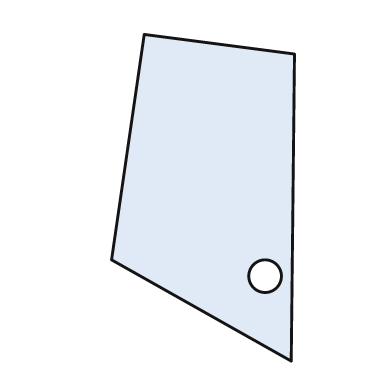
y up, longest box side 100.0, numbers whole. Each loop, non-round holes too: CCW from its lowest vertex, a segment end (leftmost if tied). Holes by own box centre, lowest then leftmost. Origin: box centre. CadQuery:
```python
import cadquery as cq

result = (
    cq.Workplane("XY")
    .moveTo(27.0, -50.0)
    .lineTo(28.0, 44.0)
    .lineTo(-18.0, 50.0)
    .lineTo(-28.0, -19.0)
    .close()
    .moveTo(19.0, -24.0)
    .circle(5.0)
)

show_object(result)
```